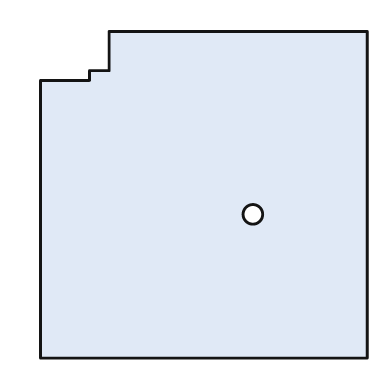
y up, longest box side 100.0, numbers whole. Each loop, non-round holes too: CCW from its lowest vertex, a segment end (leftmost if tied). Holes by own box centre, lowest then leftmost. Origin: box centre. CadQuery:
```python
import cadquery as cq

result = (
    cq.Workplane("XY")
    .moveTo(-50.0, -50.0)
    .lineTo(50.0, -50.0)
    .lineTo(50.0, 50.0)
    .lineTo(-29.0, 50.0)
    .lineTo(-29.0, 38.0)
    .lineTo(-35.0, 38.0)
    .lineTo(-35.0, 35.0)
    .lineTo(-50.0, 35.0)
    .close()
    .moveTo(15.0, -6.0)
    .circle(3.0)
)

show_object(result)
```